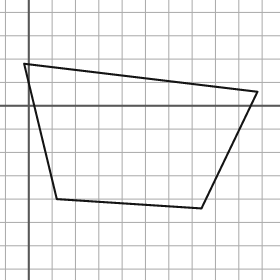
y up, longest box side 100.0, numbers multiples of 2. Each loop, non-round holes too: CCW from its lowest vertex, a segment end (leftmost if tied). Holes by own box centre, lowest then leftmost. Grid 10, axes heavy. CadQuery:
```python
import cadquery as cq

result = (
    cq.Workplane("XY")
    .moveTo(74.0, -44.0)
    .lineTo(98.0, 6.0)
    .lineTo(-2.0, 18.0)
    .lineTo(12.0, -40.0)
    .close()
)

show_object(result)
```